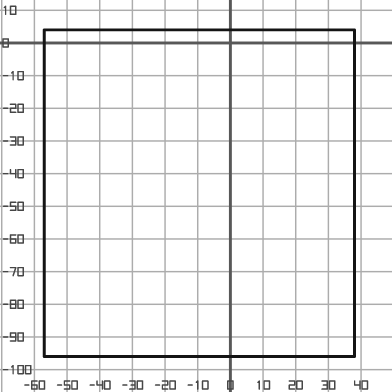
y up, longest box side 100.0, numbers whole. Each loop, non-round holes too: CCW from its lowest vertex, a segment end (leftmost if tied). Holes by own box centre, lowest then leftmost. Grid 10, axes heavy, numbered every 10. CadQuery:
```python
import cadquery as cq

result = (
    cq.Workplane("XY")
    .moveTo(-57.0, -96.0)
    .lineTo(38.0, -96.0)
    .lineTo(38.0, 4.0)
    .lineTo(-57.0, 4.0)
    .close()
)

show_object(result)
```